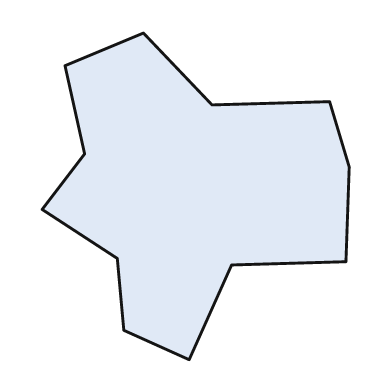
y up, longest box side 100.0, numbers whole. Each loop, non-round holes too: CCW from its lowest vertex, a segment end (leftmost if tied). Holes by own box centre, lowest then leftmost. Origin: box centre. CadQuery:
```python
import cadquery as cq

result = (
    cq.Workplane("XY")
    .moveTo(-2.0, -50.0)
    .lineTo(11.0, -21.0)
    .lineTo(46.0, -20.0)
    .lineTo(47.0, 9.0)
    .lineTo(41.0, 29.0)
    .lineTo(5.0, 28.0)
    .lineTo(-16.0, 50.0)
    .lineTo(-40.0, 40.0)
    .lineTo(-34.0, 13.0)
    .lineTo(-47.0, -4.0)
    .lineTo(-24.0, -19.0)
    .lineTo(-22.0, -41.0)
    .close()
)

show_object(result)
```